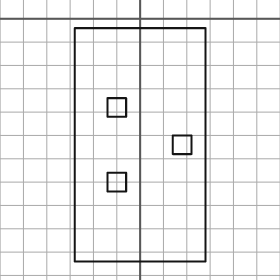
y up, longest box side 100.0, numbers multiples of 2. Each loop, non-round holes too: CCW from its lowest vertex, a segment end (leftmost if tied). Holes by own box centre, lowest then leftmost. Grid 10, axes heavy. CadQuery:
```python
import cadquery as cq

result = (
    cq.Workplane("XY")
    .moveTo(-28.0, -104.0)
    .lineTo(28.0, -104.0)
    .lineTo(28.0, -4.0)
    .lineTo(-28.0, -4.0)
    .close()
    .moveTo(-14.0, -74.0)
    .lineTo(-6.0, -74.0)
    .lineTo(-6.0, -66.0)
    .lineTo(-14.0, -66.0)
    .close()
    .moveTo(14.0, -58.0)
    .lineTo(22.0, -58.0)
    .lineTo(22.0, -50.0)
    .lineTo(14.0, -50.0)
    .close()
    .moveTo(-14.0, -42.0)
    .lineTo(-6.0, -42.0)
    .lineTo(-6.0, -34.0)
    .lineTo(-14.0, -34.0)
    .close()
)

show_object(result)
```